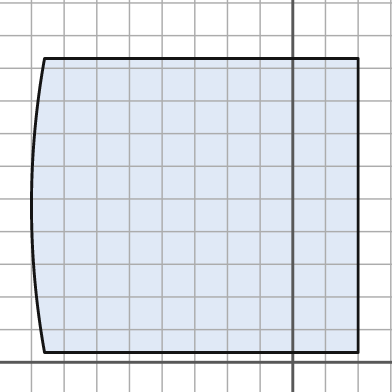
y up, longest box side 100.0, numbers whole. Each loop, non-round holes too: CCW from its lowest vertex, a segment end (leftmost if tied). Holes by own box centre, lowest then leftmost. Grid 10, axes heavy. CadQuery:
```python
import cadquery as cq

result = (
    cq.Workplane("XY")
    .moveTo(-76.0, 3.0)
    .lineTo(20.0, 3.0)
    .lineTo(20.0, 93.0)
    .lineTo(-76.0, 93.0)
    .threePointArc((-80.0, 48.0), (-76.0, 3.0))
    .close()
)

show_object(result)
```